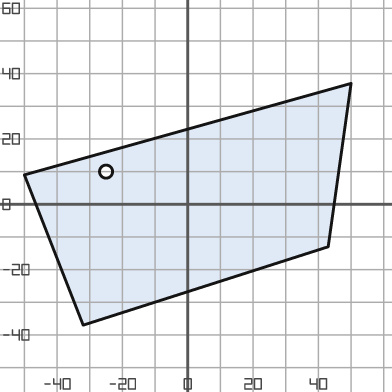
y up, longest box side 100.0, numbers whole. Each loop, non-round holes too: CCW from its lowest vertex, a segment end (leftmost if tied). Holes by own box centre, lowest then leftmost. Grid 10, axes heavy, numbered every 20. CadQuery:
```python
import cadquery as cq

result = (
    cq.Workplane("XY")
    .moveTo(-32.0, -37.0)
    .lineTo(43.0, -13.0)
    .lineTo(50.0, 37.0)
    .lineTo(-50.0, 9.0)
    .close()
    .moveTo(-25.0, 10.0)
    .circle(2.0)
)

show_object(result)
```